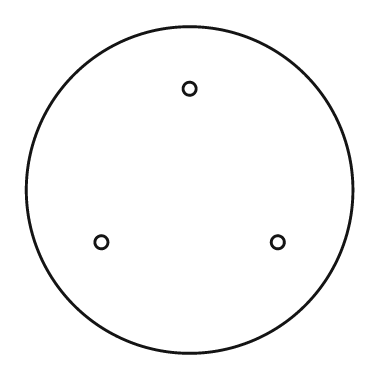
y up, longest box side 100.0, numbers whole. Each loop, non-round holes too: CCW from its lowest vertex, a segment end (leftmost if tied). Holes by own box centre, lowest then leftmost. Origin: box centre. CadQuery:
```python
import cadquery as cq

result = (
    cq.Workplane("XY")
    .moveTo(0.0, 0.0)
    .circle(50.0)
    .moveTo(-27.0, -16.0)
    .circle(2.0)
    .moveTo(27.0, -16.0)
    .circle(2.0)
    .moveTo(0.0, 31.0)
    .circle(2.0)
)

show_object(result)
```